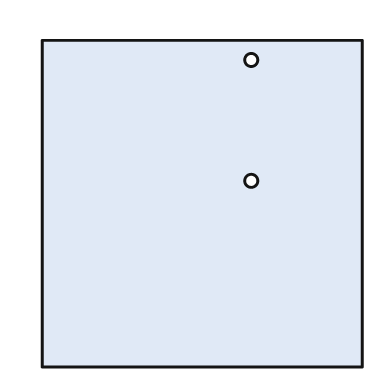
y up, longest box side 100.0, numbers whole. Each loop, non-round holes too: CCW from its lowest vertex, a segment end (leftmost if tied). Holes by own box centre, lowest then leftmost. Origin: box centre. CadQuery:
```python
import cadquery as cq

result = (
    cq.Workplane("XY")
    .moveTo(-49.0, -50.0)
    .lineTo(49.0, -50.0)
    .lineTo(49.0, 50.0)
    .lineTo(-49.0, 50.0)
    .close()
    .moveTo(15.0, 7.0)
    .circle(2.0)
    .moveTo(15.0, 44.0)
    .circle(2.0)
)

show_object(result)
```